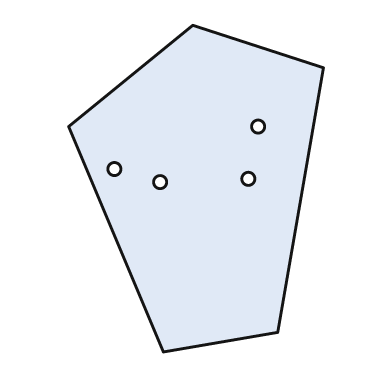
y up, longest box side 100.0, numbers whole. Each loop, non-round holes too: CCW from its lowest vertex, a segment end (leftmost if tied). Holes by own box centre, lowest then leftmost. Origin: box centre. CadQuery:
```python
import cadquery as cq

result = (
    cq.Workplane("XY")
    .moveTo(-10.0, -50.0)
    .lineTo(25.0, -44.0)
    .lineTo(39.0, 37.0)
    .lineTo(-1.0, 50.0)
    .lineTo(-39.0, 19.0)
    .close()
    .moveTo(-11.0, 2.0)
    .circle(2.0)
    .moveTo(16.0, 3.0)
    .circle(2.0)
    .moveTo(-25.0, 6.0)
    .circle(2.0)
    .moveTo(19.0, 19.0)
    .circle(2.0)
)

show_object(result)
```